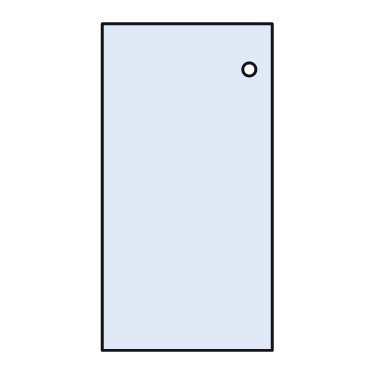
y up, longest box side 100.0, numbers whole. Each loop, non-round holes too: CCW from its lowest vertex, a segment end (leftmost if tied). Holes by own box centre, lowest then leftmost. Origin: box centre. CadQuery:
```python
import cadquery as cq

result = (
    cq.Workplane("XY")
    .moveTo(-26.0, -50.0)
    .lineTo(26.0, -50.0)
    .lineTo(26.0, 50.0)
    .lineTo(-26.0, 50.0)
    .close()
    .moveTo(19.0, 36.0)
    .circle(2.0)
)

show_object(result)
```